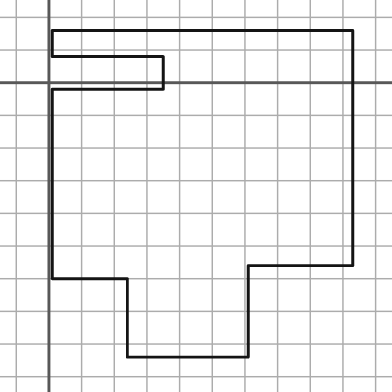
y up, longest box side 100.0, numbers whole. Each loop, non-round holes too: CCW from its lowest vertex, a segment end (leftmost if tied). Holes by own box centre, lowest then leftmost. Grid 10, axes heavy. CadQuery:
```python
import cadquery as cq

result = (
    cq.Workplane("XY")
    .moveTo(24.0, -84.0)
    .lineTo(61.0, -84.0)
    .lineTo(61.0, -56.0)
    .lineTo(93.0, -56.0)
    .lineTo(93.0, 16.0)
    .lineTo(1.0, 16.0)
    .lineTo(1.0, 8.0)
    .lineTo(35.0, 8.0)
    .lineTo(35.0, -2.0)
    .lineTo(1.0, -2.0)
    .lineTo(1.0, -60.0)
    .lineTo(24.0, -60.0)
    .close()
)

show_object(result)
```